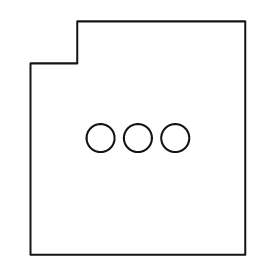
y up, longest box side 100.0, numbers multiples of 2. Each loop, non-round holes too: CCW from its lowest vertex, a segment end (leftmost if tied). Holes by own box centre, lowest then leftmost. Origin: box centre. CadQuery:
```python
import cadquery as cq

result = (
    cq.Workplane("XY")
    .moveTo(-46.0, -50.0)
    .lineTo(46.0, -50.0)
    .lineTo(46.0, 50.0)
    .lineTo(-26.0, 50.0)
    .lineTo(-26.0, 32.0)
    .lineTo(-46.0, 32.0)
    .close()
    .moveTo(-16.0, 0.0)
    .circle(6.0)
    .moveTo(0.0, 0.0)
    .circle(6.0)
    .moveTo(16.0, 0.0)
    .circle(6.0)
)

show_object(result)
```